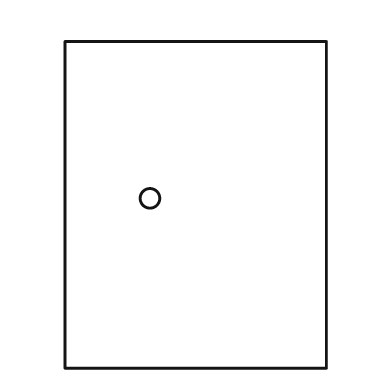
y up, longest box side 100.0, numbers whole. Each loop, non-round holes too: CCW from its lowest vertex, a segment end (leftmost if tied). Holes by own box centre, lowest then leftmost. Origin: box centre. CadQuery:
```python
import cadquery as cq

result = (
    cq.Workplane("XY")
    .moveTo(-40.0, -50.0)
    .lineTo(40.0, -50.0)
    .lineTo(40.0, 50.0)
    .lineTo(-40.0, 50.0)
    .close()
    .moveTo(-14.0, 2.0)
    .circle(3.0)
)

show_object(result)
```